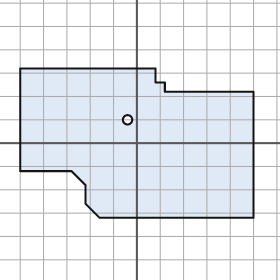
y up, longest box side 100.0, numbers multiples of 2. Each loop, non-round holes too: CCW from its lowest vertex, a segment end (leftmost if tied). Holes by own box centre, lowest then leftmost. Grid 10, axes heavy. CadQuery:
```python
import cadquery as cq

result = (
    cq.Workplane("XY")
    .moveTo(-16.0, -32.0)
    .lineTo(50.0, -32.0)
    .lineTo(50.0, 22.0)
    .lineTo(12.0, 22.0)
    .lineTo(12.0, 26.0)
    .lineTo(8.0, 26.0)
    .lineTo(8.0, 32.0)
    .lineTo(-50.0, 32.0)
    .lineTo(-50.0, -12.0)
    .lineTo(-28.0, -12.0)
    .lineTo(-22.0, -18.0)
    .lineTo(-22.0, -26.0)
    .close()
    .moveTo(-4.0, 10.0)
    .circle(2.0)
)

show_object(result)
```